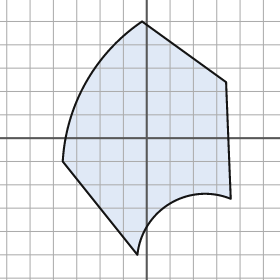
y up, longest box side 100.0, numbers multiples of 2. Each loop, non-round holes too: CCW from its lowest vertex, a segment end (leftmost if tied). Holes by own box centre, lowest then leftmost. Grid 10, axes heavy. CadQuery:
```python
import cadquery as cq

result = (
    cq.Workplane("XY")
    .moveTo(-4.0, -50.0)
    .threePointArc((10.0, -28.0), (36.0, -26.0))
    .lineTo(34.0, 24.0)
    .lineTo(-2.0, 50.0)
    .threePointArc((-26.0, 24.0), (-36.0, -10.0))
    .close()
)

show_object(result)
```